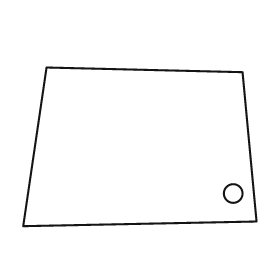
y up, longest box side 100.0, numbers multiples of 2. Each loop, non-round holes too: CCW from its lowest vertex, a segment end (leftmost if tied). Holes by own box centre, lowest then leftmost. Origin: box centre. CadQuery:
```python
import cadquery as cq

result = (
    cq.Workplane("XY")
    .moveTo(-50.0, -34.0)
    .lineTo(50.0, -32.0)
    .lineTo(44.0, 32.0)
    .lineTo(-40.0, 34.0)
    .close()
    .moveTo(40.0, -20.0)
    .circle(4.0)
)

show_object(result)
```